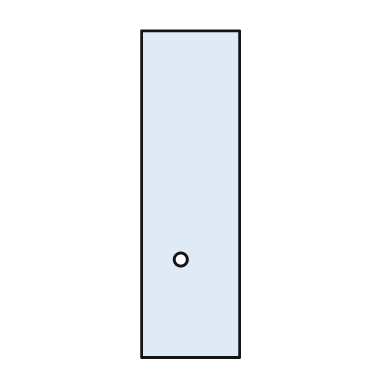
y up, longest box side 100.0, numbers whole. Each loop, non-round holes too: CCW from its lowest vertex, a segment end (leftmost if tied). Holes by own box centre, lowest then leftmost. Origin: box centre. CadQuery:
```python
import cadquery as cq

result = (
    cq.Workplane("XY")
    .moveTo(-15.0, -50.0)
    .lineTo(15.0, -50.0)
    .lineTo(15.0, 50.0)
    .lineTo(-15.0, 50.0)
    .close()
    .moveTo(-3.0, -20.0)
    .circle(2.0)
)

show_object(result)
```